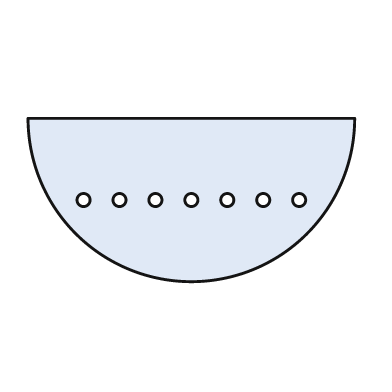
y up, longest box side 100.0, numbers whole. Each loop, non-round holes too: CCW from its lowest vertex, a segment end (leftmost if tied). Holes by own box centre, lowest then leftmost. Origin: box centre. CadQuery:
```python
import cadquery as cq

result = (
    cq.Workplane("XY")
    .moveTo(-50.0, 25.0)
    .threePointArc((0.0, -25.0), (50.0, 25.0))
    .close()
    .moveTo(-33.0, 0.0)
    .circle(2.0)
    .moveTo(-22.0, 0.0)
    .circle(2.0)
    .moveTo(-11.0, 0.0)
    .circle(2.0)
    .moveTo(0.0, 0.0)
    .circle(2.0)
    .moveTo(11.0, 0.0)
    .circle(2.0)
    .moveTo(22.0, 0.0)
    .circle(2.0)
    .moveTo(33.0, 0.0)
    .circle(2.0)
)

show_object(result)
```